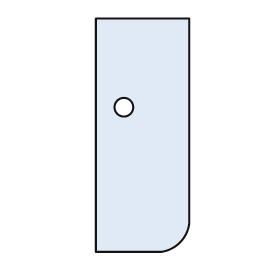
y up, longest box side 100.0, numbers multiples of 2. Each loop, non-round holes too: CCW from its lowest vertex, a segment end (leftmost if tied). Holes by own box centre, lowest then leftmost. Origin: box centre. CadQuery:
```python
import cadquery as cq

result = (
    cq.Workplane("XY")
    .moveTo(-20.0, -50.0)
    .lineTo(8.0, -50.0)
    .threePointArc((16.0, -46.0), (20.0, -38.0))
    .lineTo(20.0, 50.0)
    .lineTo(-20.0, 50.0)
    .close()
    .moveTo(-8.0, 12.0)
    .circle(4.0)
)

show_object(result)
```